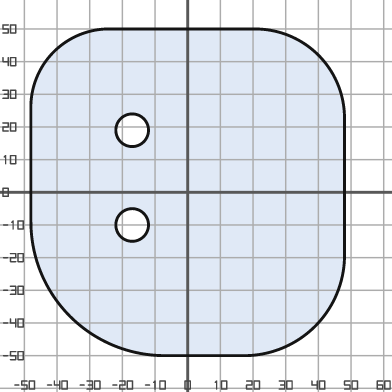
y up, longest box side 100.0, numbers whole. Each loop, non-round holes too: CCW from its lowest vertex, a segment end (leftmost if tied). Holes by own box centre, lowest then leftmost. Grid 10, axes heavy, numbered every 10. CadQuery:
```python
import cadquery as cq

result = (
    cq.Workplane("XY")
    .moveTo(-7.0, -50.0)
    .lineTo(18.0, -50.0)
    .threePointArc((39.0, -41.0), (48.0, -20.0))
    .lineTo(48.0, 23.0)
    .threePointArc((40.0, 42.0), (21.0, 50.0))
    .lineTo(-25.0, 50.0)
    .threePointArc((-41.0, 43.0), (-48.0, 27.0))
    .lineTo(-48.0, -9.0)
    .threePointArc((-36.0, -38.0), (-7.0, -50.0))
    .close()
    .moveTo(-17.0, -10.0)
    .circle(5.0)
    .moveTo(-17.0, 19.0)
    .circle(5.0)
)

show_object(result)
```